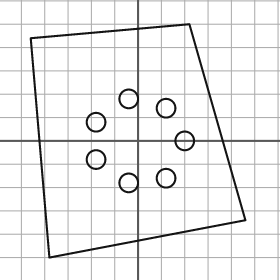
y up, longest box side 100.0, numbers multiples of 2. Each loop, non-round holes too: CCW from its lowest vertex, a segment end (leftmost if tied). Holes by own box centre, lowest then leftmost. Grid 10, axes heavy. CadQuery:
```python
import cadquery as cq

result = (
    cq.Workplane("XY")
    .moveTo(-38.0, -50.0)
    .lineTo(46.0, -34.0)
    .lineTo(22.0, 50.0)
    .lineTo(-46.0, 44.0)
    .close()
    .moveTo(-4.0, -18.0)
    .circle(4.0)
    .moveTo(12.0, -16.0)
    .circle(4.0)
    .moveTo(-18.0, -8.0)
    .circle(4.0)
    .moveTo(20.0, 0.0)
    .circle(4.0)
    .moveTo(-18.0, 8.0)
    .circle(4.0)
    .moveTo(12.0, 14.0)
    .circle(4.0)
    .moveTo(-4.0, 18.0)
    .circle(4.0)
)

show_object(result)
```